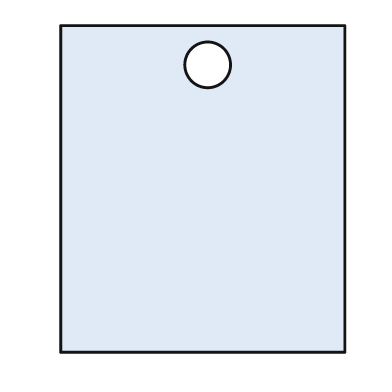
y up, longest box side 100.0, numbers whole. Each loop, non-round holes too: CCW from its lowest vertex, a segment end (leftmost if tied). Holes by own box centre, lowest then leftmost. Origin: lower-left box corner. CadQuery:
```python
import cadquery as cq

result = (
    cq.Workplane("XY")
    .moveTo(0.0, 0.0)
    .lineTo(87.0, 0.0)
    .lineTo(87.0, 100.0)
    .lineTo(0.0, 100.0)
    .close()
    .moveTo(45.0, 88.0)
    .circle(7.0)
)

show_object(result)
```